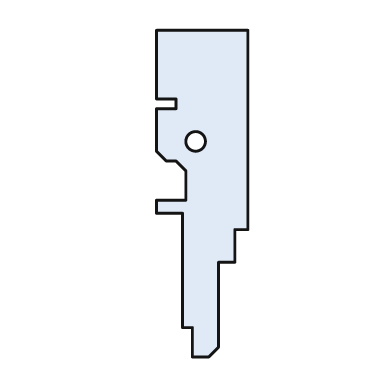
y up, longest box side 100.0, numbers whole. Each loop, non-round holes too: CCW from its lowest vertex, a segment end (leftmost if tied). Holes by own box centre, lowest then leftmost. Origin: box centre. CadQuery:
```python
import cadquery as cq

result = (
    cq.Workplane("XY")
    .moveTo(-3.0, -50.0)
    .lineTo(2.0, -50.0)
    .lineTo(5.0, -47.0)
    .lineTo(5.0, -21.0)
    .lineTo(10.0, -21.0)
    .lineTo(10.0, -11.0)
    .lineTo(14.0, -11.0)
    .lineTo(14.0, 50.0)
    .lineTo(-14.0, 50.0)
    .lineTo(-14.0, 29.0)
    .lineTo(-8.0, 29.0)
    .lineTo(-8.0, 26.0)
    .lineTo(-14.0, 26.0)
    .lineTo(-14.0, 13.0)
    .lineTo(-11.0, 10.0)
    .lineTo(-8.0, 10.0)
    .lineTo(-5.0, 7.0)
    .lineTo(-5.0, -2.0)
    .lineTo(-14.0, -2.0)
    .lineTo(-14.0, -6.0)
    .lineTo(-6.0, -6.0)
    .lineTo(-6.0, -41.0)
    .lineTo(-3.0, -41.0)
    .close()
    .moveTo(-2.0, 16.0)
    .circle(3.0)
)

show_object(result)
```